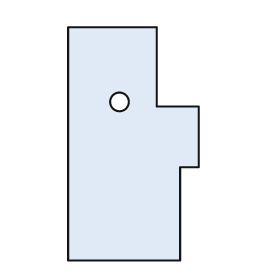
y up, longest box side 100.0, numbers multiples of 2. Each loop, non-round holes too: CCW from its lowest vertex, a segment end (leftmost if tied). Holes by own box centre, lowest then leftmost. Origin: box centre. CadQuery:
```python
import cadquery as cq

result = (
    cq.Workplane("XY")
    .moveTo(-28.0, -50.0)
    .lineTo(20.0, -50.0)
    .lineTo(20.0, -10.0)
    .lineTo(28.0, -10.0)
    .lineTo(28.0, 16.0)
    .lineTo(10.0, 16.0)
    .lineTo(10.0, 50.0)
    .lineTo(-28.0, 50.0)
    .close()
    .moveTo(-6.0, 18.0)
    .circle(4.0)
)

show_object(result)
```